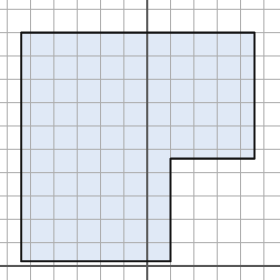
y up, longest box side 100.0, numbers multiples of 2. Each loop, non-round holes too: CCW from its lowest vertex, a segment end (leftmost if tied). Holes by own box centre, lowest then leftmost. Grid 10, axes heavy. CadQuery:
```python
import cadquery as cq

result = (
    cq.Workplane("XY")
    .moveTo(-54.0, 2.0)
    .lineTo(10.0, 2.0)
    .lineTo(10.0, 46.0)
    .lineTo(46.0, 46.0)
    .lineTo(46.0, 100.0)
    .lineTo(-54.0, 100.0)
    .close()
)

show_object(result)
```